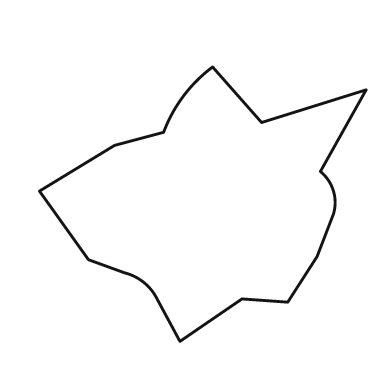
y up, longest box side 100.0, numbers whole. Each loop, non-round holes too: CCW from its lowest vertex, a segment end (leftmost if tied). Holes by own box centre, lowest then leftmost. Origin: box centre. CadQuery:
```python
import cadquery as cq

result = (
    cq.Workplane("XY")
    .moveTo(-7.0, -42.0)
    .lineTo(12.0, -29.0)
    .lineTo(26.0, -30.0)
    .lineTo(35.0, -16.0)
    .lineTo(40.0, -3.0)
    .threePointArc((40.0, 4.0), (36.0, 10.0))
    .lineTo(50.0, 35.0)
    .lineTo(18.0, 25.0)
    .lineTo(3.0, 42.0)
    .threePointArc((-6.0, 33.0), (-12.0, 22.0))
    .lineTo(-27.0, 18.0)
    .lineTo(-50.0, 4.0)
    .lineTo(-35.0, -17.0)
    .lineTo(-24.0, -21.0)
    .threePointArc((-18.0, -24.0), (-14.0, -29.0))
    .close()
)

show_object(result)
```